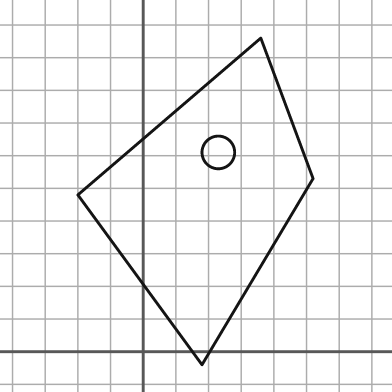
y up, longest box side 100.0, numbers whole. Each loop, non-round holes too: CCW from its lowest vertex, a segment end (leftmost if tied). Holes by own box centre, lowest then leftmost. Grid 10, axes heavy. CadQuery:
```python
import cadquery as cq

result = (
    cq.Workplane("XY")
    .moveTo(18.0, -4.0)
    .lineTo(52.0, 53.0)
    .lineTo(36.0, 96.0)
    .lineTo(-20.0, 48.0)
    .close()
    .moveTo(23.0, 61.0)
    .circle(5.0)
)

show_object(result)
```